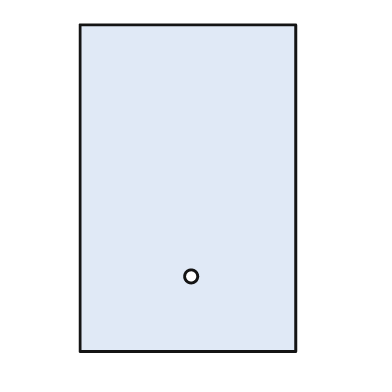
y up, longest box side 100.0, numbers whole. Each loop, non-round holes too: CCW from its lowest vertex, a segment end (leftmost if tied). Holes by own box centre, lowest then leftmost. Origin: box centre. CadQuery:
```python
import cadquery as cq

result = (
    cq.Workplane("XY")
    .moveTo(-33.0, -50.0)
    .lineTo(33.0, -50.0)
    .lineTo(33.0, 50.0)
    .lineTo(-33.0, 50.0)
    .close()
    .moveTo(1.0, -27.0)
    .circle(2.0)
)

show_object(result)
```